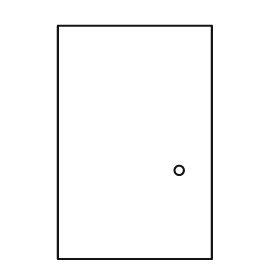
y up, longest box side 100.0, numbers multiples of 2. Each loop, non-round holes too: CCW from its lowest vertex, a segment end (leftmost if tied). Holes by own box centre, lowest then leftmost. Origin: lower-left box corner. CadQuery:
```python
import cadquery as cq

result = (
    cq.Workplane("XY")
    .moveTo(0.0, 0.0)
    .lineTo(66.0, 0.0)
    .lineTo(66.0, 100.0)
    .lineTo(0.0, 100.0)
    .close()
    .moveTo(52.0, 38.0)
    .circle(2.0)
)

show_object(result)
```